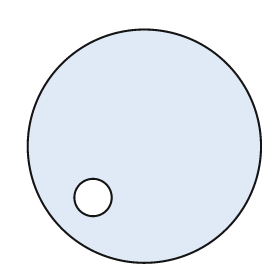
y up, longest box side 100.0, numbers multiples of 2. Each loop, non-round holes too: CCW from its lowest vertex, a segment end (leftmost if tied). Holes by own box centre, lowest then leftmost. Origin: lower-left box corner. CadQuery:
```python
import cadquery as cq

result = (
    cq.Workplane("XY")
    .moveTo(50.0, 50.0)
    .circle(50.0)
    .moveTo(28.0, 28.0)
    .circle(8.0)
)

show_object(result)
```